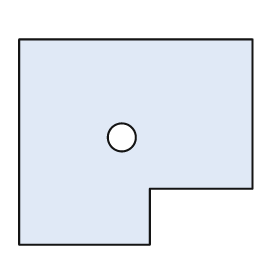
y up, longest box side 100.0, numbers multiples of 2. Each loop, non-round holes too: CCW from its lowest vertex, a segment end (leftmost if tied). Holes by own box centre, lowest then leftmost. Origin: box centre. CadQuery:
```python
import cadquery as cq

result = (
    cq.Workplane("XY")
    .moveTo(-50.0, -44.0)
    .lineTo(6.0, -44.0)
    .lineTo(6.0, -20.0)
    .lineTo(50.0, -20.0)
    .lineTo(50.0, 44.0)
    .lineTo(-50.0, 44.0)
    .close()
    .moveTo(-6.0, 2.0)
    .circle(6.0)
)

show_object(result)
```